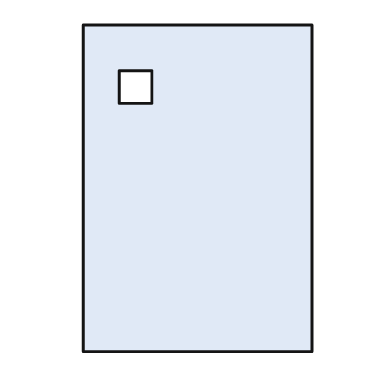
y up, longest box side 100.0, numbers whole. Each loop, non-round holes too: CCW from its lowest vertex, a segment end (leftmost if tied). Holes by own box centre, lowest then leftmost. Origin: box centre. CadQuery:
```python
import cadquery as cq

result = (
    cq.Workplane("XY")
    .moveTo(-35.0, -50.0)
    .lineTo(35.0, -50.0)
    .lineTo(35.0, 50.0)
    .lineTo(-35.0, 50.0)
    .close()
    .moveTo(-24.0, 26.0)
    .lineTo(-14.0, 26.0)
    .lineTo(-14.0, 36.0)
    .lineTo(-24.0, 36.0)
    .close()
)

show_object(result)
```